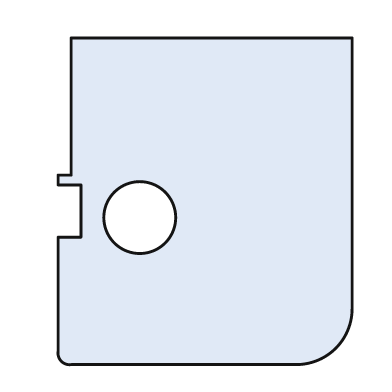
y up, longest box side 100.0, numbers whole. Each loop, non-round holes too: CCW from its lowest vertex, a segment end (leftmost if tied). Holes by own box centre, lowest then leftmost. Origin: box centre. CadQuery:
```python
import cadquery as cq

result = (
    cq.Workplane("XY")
    .moveTo(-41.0, -50.0)
    .lineTo(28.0, -50.0)
    .threePointArc((40.0, -45.0), (45.0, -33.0))
    .lineTo(45.0, 50.0)
    .lineTo(-41.0, 50.0)
    .lineTo(-41.0, 8.0)
    .lineTo(-45.0, 8.0)
    .lineTo(-45.0, 5.0)
    .lineTo(-38.0, 5.0)
    .lineTo(-38.0, -11.0)
    .lineTo(-45.0, -11.0)
    .lineTo(-45.0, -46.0)
    .threePointArc((-44.0, -49.0), (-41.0, -50.0))
    .close()
    .moveTo(-20.0, -5.0)
    .circle(11.0)
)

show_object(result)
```